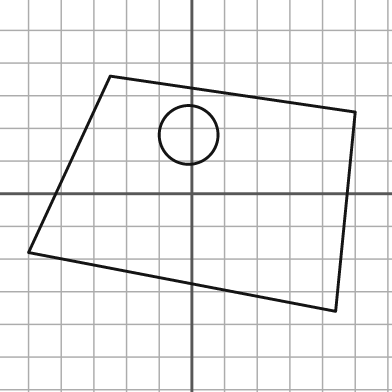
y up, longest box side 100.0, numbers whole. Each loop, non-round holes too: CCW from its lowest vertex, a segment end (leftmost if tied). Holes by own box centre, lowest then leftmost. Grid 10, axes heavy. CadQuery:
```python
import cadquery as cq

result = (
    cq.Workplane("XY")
    .moveTo(44.0, -36.0)
    .lineTo(50.0, 25.0)
    .lineTo(-25.0, 36.0)
    .lineTo(-50.0, -18.0)
    .close()
    .moveTo(-1.0, 18.0)
    .circle(9.0)
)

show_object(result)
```